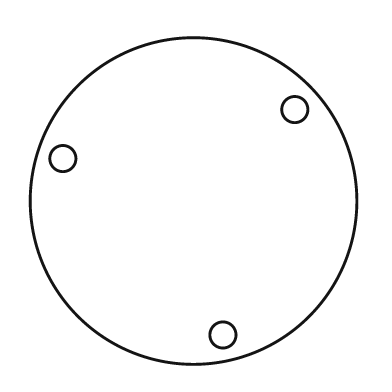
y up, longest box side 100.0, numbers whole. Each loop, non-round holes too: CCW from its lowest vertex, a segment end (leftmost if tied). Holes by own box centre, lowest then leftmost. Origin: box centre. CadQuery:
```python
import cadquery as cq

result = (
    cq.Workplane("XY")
    .moveTo(0.0, 0.0)
    .circle(50.0)
    .moveTo(9.0, -41.0)
    .circle(4.0)
    .moveTo(-40.0, 13.0)
    .circle(4.0)
    .moveTo(31.0, 28.0)
    .circle(4.0)
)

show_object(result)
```